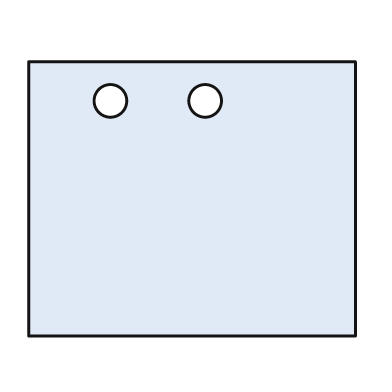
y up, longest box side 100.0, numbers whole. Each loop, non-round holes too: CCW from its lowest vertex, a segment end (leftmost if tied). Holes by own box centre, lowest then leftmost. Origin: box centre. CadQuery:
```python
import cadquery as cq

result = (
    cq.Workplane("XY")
    .moveTo(-50.0, -42.0)
    .lineTo(50.0, -42.0)
    .lineTo(50.0, 42.0)
    .lineTo(-50.0, 42.0)
    .close()
    .moveTo(-25.0, 30.0)
    .circle(5.0)
    .moveTo(4.0, 30.0)
    .circle(5.0)
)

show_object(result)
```